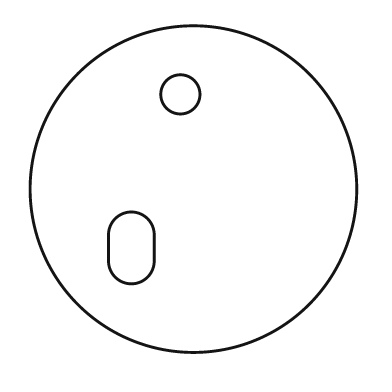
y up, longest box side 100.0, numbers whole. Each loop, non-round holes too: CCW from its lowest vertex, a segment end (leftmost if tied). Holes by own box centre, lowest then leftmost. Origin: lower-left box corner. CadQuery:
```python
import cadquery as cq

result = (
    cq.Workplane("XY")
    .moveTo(50.0, 50.0)
    .circle(50.0)
    .moveTo(24.0, 28.0)
    .threePointArc((31.0, 21.0), (38.0, 28.0))
    .lineTo(38.0, 36.0)
    .threePointArc((31.0, 43.0), (24.0, 36.0))
    .close()
    .moveTo(46.0, 79.0)
    .circle(6.0)
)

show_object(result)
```